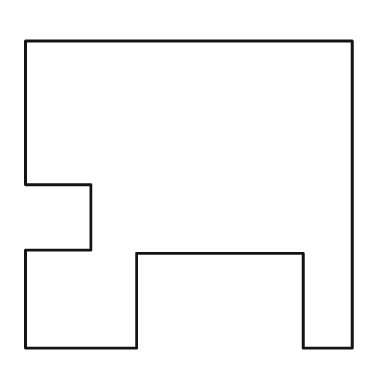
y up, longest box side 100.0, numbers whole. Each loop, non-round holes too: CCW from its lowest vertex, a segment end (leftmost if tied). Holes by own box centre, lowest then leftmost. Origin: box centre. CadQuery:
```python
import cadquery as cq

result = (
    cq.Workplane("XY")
    .moveTo(-50.0, -47.0)
    .lineTo(-16.0, -47.0)
    .lineTo(-16.0, -18.0)
    .lineTo(35.0, -18.0)
    .lineTo(35.0, -47.0)
    .lineTo(50.0, -47.0)
    .lineTo(50.0, 47.0)
    .lineTo(-50.0, 47.0)
    .lineTo(-50.0, 3.0)
    .lineTo(-30.0, 3.0)
    .lineTo(-30.0, -17.0)
    .lineTo(-50.0, -17.0)
    .close()
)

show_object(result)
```